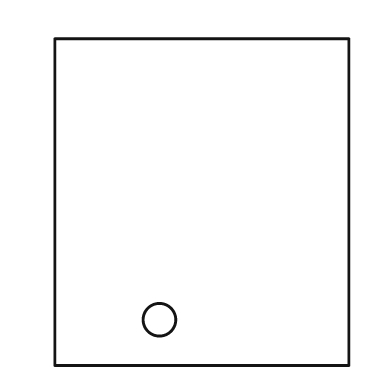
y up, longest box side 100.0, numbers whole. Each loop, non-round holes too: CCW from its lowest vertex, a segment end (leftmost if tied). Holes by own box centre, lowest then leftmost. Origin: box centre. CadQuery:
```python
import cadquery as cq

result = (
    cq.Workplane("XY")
    .moveTo(-45.0, -50.0)
    .lineTo(45.0, -50.0)
    .lineTo(45.0, 50.0)
    .lineTo(-45.0, 50.0)
    .close()
    .moveTo(-13.0, -36.0)
    .circle(5.0)
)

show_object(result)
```